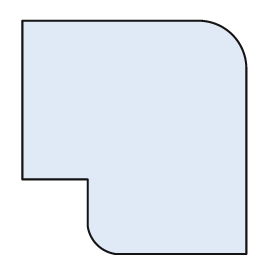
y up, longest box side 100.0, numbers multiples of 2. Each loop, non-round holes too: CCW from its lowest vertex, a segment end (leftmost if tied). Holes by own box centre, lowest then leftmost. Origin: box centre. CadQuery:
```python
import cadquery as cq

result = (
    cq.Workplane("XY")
    .moveTo(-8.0, -50.0)
    .lineTo(48.0, -50.0)
    .lineTo(48.0, 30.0)
    .threePointArc((42.0, 44.0), (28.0, 50.0))
    .lineTo(-48.0, 50.0)
    .lineTo(-48.0, -18.0)
    .lineTo(-20.0, -18.0)
    .lineTo(-20.0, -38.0)
    .threePointArc((-16.0, -46.0), (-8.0, -50.0))
    .close()
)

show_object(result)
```